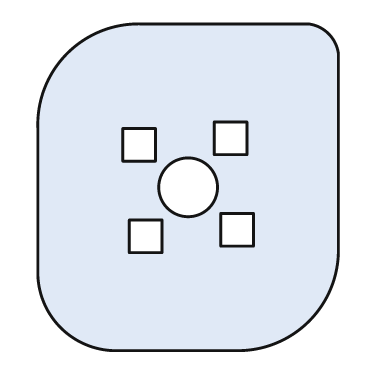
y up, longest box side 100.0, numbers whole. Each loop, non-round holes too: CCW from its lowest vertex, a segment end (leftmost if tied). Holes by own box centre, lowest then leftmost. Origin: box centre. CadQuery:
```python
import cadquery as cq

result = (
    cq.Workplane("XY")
    .moveTo(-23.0, -50.0)
    .lineTo(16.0, -50.0)
    .threePointArc((37.0, -41.0), (46.0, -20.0))
    .lineTo(46.0, 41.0)
    .threePointArc((43.0, 47.0), (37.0, 50.0))
    .lineTo(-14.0, 50.0)
    .threePointArc((-37.0, 41.0), (-46.0, 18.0))
    .lineTo(-46.0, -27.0)
    .threePointArc((-39.0, -43.0), (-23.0, -50.0))
    .close()
    .moveTo(-18.0, -20.0)
    .lineTo(-8.0, -20.0)
    .lineTo(-8.0, -10.0)
    .lineTo(-18.0, -10.0)
    .close()
    .moveTo(10.0, -18.0)
    .lineTo(20.0, -18.0)
    .lineTo(20.0, -8.0)
    .lineTo(10.0, -8.0)
    .close()
    .moveTo(0.0, 0.0)
    .circle(9.0)
    .moveTo(-20.0, 8.0)
    .lineTo(-10.0, 8.0)
    .lineTo(-10.0, 18.0)
    .lineTo(-20.0, 18.0)
    .close()
    .moveTo(8.0, 10.0)
    .lineTo(18.0, 10.0)
    .lineTo(18.0, 20.0)
    .lineTo(8.0, 20.0)
    .close()
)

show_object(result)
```